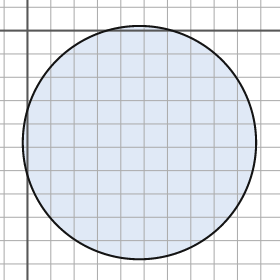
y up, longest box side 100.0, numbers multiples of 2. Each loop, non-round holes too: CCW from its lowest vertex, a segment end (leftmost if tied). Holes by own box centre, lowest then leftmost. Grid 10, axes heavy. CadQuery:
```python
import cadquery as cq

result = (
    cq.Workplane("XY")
    .moveTo(48.0, -48.0)
    .circle(50.0)
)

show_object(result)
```